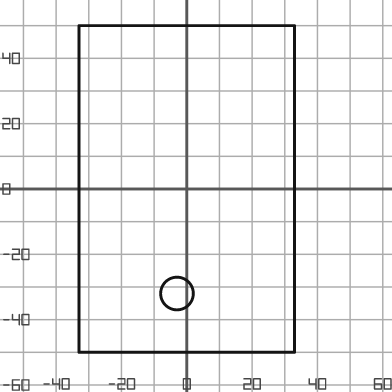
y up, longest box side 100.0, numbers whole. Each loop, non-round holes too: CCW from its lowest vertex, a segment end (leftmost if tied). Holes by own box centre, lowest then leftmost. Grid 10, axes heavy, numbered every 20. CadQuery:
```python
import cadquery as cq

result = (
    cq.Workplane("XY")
    .moveTo(-33.0, -50.0)
    .lineTo(33.0, -50.0)
    .lineTo(33.0, 50.0)
    .lineTo(-33.0, 50.0)
    .close()
    .moveTo(-3.0, -32.0)
    .circle(5.0)
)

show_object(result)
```